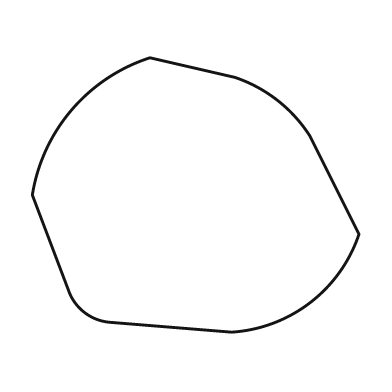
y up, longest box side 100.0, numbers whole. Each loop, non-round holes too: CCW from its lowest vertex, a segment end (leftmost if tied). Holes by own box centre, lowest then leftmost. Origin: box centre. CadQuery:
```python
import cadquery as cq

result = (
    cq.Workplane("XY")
    .moveTo(11.0, -42.0)
    .threePointArc((35.0, -33.0), (50.0, -12.0))
    .lineTo(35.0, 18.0)
    .threePointArc((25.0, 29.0), (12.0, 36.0))
    .lineTo(-14.0, 42.0)
    .threePointArc((-38.0, 26.0), (-50.0, 0.0))
    .lineTo(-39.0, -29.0)
    .threePointArc((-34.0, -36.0), (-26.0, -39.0))
    .close()
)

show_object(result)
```